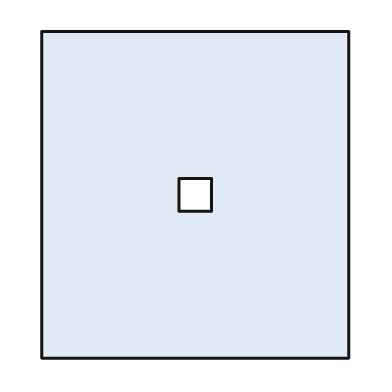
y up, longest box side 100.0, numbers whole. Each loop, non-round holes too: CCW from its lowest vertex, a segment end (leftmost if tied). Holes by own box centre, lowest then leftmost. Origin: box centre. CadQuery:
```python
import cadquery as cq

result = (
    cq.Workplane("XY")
    .moveTo(-47.0, -50.0)
    .lineTo(47.0, -50.0)
    .lineTo(47.0, 50.0)
    .lineTo(-47.0, 50.0)
    .close()
    .moveTo(-5.0, -5.0)
    .lineTo(5.0, -5.0)
    .lineTo(5.0, 5.0)
    .lineTo(-5.0, 5.0)
    .close()
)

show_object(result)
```